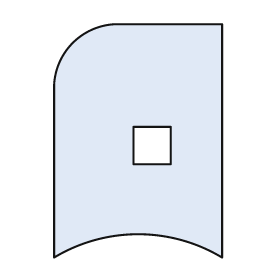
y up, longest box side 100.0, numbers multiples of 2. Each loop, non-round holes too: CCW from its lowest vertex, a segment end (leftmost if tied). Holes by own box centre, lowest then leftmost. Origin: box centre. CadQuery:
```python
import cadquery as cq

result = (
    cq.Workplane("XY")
    .moveTo(-36.0, -50.0)
    .threePointArc((0.0, -40.0), (36.0, -50.0))
    .lineTo(36.0, 50.0)
    .lineTo(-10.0, 50.0)
    .threePointArc((-28.0, 42.0), (-36.0, 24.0))
    .close()
    .moveTo(-2.0, -10.0)
    .lineTo(14.0, -10.0)
    .lineTo(14.0, 6.0)
    .lineTo(-2.0, 6.0)
    .close()
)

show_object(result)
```